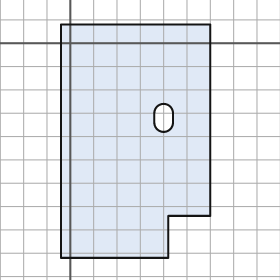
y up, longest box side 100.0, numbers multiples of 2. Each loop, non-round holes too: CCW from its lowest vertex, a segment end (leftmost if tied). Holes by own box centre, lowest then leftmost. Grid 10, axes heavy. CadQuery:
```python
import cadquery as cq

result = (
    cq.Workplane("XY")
    .moveTo(-4.0, -92.0)
    .lineTo(42.0, -92.0)
    .lineTo(42.0, -74.0)
    .lineTo(60.0, -74.0)
    .lineTo(60.0, 8.0)
    .lineTo(-4.0, 8.0)
    .close()
    .moveTo(36.0, -34.0)
    .threePointArc((40.0, -38.0), (44.0, -34.0))
    .lineTo(44.0, -30.0)
    .threePointArc((40.0, -26.0), (36.0, -30.0))
    .close()
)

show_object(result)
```